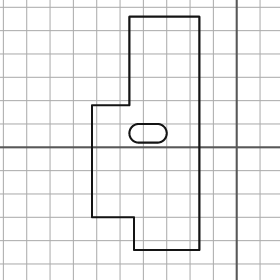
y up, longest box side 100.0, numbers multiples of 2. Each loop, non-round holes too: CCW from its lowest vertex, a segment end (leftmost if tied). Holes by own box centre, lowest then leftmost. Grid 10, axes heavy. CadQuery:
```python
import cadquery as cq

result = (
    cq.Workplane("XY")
    .moveTo(-44.0, -44.0)
    .lineTo(-16.0, -44.0)
    .lineTo(-16.0, 56.0)
    .lineTo(-46.0, 56.0)
    .lineTo(-46.0, 18.0)
    .lineTo(-62.0, 18.0)
    .lineTo(-62.0, -30.0)
    .lineTo(-44.0, -30.0)
    .close()
    .moveTo(-42.0, 2.0)
    .lineTo(-34.0, 2.0)
    .threePointArc((-30.0, 6.0), (-34.0, 10.0))
    .lineTo(-42.0, 10.0)
    .threePointArc((-46.0, 6.0), (-42.0, 2.0))
    .close()
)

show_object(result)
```